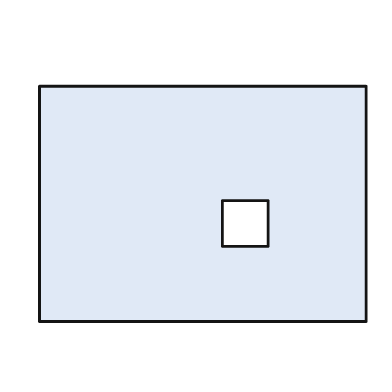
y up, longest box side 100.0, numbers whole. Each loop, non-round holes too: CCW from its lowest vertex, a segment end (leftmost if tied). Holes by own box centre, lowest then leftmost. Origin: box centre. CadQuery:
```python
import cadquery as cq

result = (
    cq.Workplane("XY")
    .moveTo(-50.0, -36.0)
    .lineTo(50.0, -36.0)
    .lineTo(50.0, 36.0)
    .lineTo(-50.0, 36.0)
    .close()
    .moveTo(6.0, -13.0)
    .lineTo(20.0, -13.0)
    .lineTo(20.0, 1.0)
    .lineTo(6.0, 1.0)
    .close()
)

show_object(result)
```